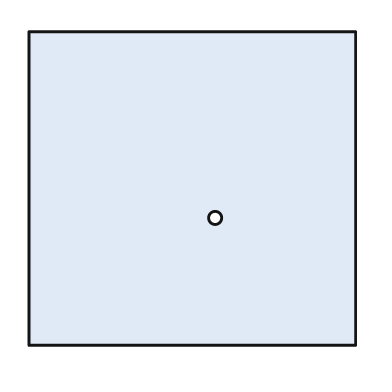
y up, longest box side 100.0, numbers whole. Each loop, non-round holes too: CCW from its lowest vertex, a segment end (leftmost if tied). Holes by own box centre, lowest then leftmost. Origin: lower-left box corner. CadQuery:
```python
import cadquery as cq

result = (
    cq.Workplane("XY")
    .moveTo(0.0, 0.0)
    .lineTo(100.0, 0.0)
    .lineTo(100.0, 96.0)
    .lineTo(0.0, 96.0)
    .close()
    .moveTo(57.0, 39.0)
    .circle(2.0)
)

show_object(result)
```